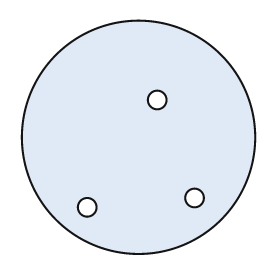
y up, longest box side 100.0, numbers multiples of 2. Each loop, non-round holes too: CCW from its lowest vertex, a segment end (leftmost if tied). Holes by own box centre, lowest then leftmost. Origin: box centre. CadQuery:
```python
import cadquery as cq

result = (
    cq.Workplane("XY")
    .moveTo(0.0, 0.0)
    .circle(50.0)
    .moveTo(-22.0, -30.0)
    .circle(4.0)
    .moveTo(24.0, -26.0)
    .circle(4.0)
    .moveTo(8.0, 16.0)
    .circle(4.0)
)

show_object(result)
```